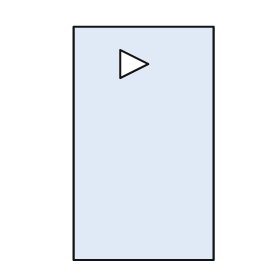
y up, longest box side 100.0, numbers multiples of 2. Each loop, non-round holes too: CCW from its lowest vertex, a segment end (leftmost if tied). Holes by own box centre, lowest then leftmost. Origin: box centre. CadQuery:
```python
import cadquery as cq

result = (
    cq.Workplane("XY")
    .moveTo(-30.0, -50.0)
    .lineTo(30.0, -50.0)
    .lineTo(30.0, 50.0)
    .lineTo(-30.0, 50.0)
    .close()
    .moveTo(-10.0, 28.0)
    .lineTo(2.0, 34.0)
    .lineTo(-10.0, 40.0)
    .close()
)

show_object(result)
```